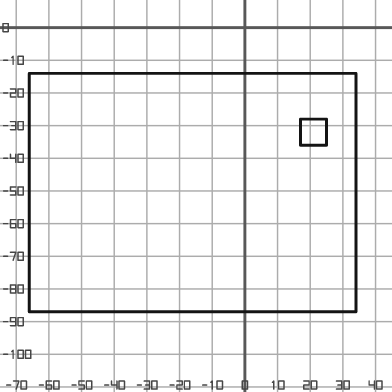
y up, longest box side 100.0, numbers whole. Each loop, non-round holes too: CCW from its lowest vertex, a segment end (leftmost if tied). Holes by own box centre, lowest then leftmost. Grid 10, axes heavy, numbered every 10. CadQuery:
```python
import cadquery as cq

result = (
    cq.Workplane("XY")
    .moveTo(-66.0, -87.0)
    .lineTo(34.0, -87.0)
    .lineTo(34.0, -14.0)
    .lineTo(-66.0, -14.0)
    .close()
    .moveTo(17.0, -36.0)
    .lineTo(25.0, -36.0)
    .lineTo(25.0, -28.0)
    .lineTo(17.0, -28.0)
    .close()
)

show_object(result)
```